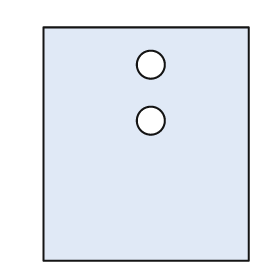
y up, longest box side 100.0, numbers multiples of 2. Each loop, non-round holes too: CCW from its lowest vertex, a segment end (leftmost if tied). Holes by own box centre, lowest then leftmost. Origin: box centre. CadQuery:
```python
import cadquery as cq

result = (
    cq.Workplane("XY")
    .moveTo(-44.0, -50.0)
    .lineTo(44.0, -50.0)
    .lineTo(44.0, 50.0)
    .lineTo(-44.0, 50.0)
    .close()
    .moveTo(2.0, 10.0)
    .circle(6.0)
    .moveTo(2.0, 34.0)
    .circle(6.0)
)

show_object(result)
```